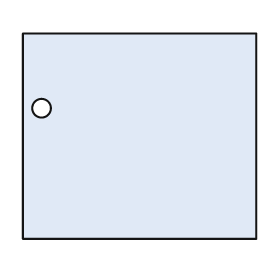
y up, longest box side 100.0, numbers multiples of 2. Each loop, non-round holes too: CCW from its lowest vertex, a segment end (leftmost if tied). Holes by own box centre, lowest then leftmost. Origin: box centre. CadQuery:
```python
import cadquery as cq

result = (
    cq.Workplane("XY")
    .moveTo(-50.0, -44.0)
    .lineTo(50.0, -44.0)
    .lineTo(50.0, 44.0)
    .lineTo(-50.0, 44.0)
    .close()
    .moveTo(-42.0, 12.0)
    .circle(4.0)
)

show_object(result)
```